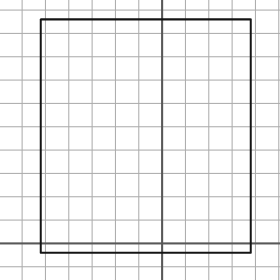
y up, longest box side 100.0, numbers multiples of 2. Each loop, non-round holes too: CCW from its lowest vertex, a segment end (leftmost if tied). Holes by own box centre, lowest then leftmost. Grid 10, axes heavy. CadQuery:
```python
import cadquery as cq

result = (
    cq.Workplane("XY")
    .moveTo(-52.0, -4.0)
    .lineTo(38.0, -4.0)
    .lineTo(38.0, 96.0)
    .lineTo(-52.0, 96.0)
    .close()
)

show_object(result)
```